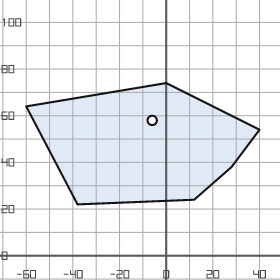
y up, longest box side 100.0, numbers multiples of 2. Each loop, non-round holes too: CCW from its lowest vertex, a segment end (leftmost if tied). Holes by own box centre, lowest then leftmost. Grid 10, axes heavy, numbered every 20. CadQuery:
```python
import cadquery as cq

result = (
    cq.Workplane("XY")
    .moveTo(-38.0, 22.0)
    .lineTo(12.0, 24.0)
    .lineTo(28.0, 38.0)
    .lineTo(40.0, 54.0)
    .lineTo(0.0, 74.0)
    .lineTo(-60.0, 64.0)
    .close()
    .moveTo(-6.0, 58.0)
    .circle(2.0)
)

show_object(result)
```